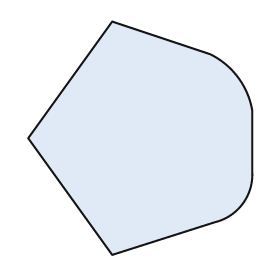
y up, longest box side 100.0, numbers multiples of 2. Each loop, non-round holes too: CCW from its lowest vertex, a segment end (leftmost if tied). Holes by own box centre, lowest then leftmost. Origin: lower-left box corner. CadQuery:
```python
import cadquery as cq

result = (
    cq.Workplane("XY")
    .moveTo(36.0, 0.0)
    .lineTo(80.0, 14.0)
    .threePointArc((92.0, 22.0), (96.0, 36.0))
    .lineTo(96.0, 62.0)
    .threePointArc((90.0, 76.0), (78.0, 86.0))
    .lineTo(36.0, 100.0)
    .lineTo(0.0, 50.0)
    .close()
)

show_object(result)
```